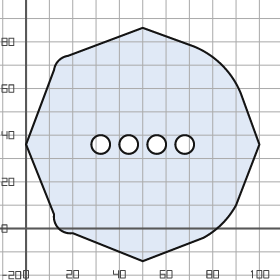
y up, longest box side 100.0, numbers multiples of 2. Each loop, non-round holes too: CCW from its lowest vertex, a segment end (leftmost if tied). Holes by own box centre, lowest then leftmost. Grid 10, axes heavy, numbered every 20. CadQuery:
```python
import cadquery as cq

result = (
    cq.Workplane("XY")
    .moveTo(50.0, -14.0)
    .lineTo(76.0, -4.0)
    .threePointArc((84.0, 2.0), (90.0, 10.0))
    .lineTo(100.0, 36.0)
    .lineTo(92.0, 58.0)
    .threePointArc((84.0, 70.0), (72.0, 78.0))
    .lineTo(50.0, 86.0)
    .lineTo(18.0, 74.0)
    .threePointArc((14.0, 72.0), (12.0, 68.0))
    .lineTo(0.0, 36.0)
    .lineTo(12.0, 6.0)
    .threePointArc((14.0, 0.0), (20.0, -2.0))
    .close()
    .moveTo(32.0, 36.0)
    .circle(4.0)
    .moveTo(44.0, 36.0)
    .circle(4.0)
    .moveTo(56.0, 36.0)
    .circle(4.0)
    .moveTo(68.0, 36.0)
    .circle(4.0)
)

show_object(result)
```